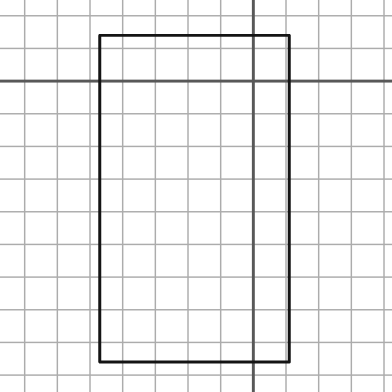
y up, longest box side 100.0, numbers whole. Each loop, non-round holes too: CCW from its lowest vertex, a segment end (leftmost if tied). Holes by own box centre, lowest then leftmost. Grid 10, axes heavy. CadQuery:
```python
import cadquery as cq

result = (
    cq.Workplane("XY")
    .moveTo(-47.0, -86.0)
    .lineTo(11.0, -86.0)
    .lineTo(11.0, 14.0)
    .lineTo(-47.0, 14.0)
    .close()
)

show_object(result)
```